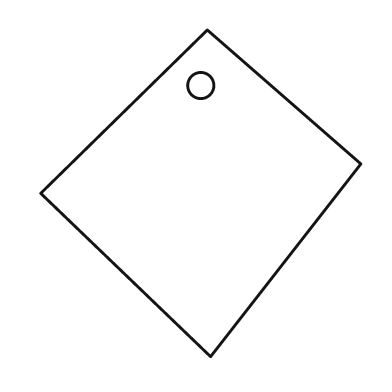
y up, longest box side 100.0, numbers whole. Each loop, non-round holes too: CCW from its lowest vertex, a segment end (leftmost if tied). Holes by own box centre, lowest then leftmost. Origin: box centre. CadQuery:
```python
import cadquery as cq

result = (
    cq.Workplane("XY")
    .moveTo(3.0, -50.0)
    .lineTo(49.0, 9.0)
    .lineTo(2.0, 50.0)
    .lineTo(-49.0, 0.0)
    .close()
    .moveTo(0.0, 33.0)
    .circle(4.0)
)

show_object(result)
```